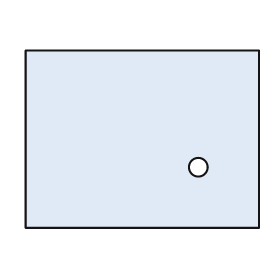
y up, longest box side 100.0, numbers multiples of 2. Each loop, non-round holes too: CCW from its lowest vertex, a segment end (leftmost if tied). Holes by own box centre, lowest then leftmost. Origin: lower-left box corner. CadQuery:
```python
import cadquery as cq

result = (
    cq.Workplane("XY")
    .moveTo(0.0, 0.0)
    .lineTo(100.0, 0.0)
    .lineTo(100.0, 76.0)
    .lineTo(0.0, 76.0)
    .close()
    .moveTo(74.0, 26.0)
    .circle(4.0)
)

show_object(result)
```